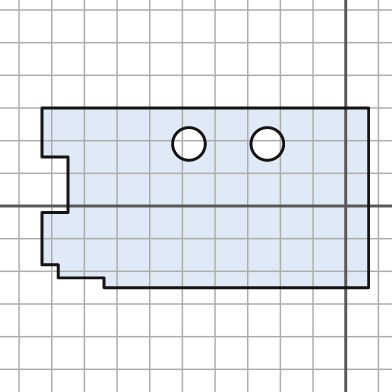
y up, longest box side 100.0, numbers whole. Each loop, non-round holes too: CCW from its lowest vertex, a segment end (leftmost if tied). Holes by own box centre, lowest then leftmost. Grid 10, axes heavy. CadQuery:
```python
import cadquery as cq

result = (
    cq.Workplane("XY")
    .moveTo(-74.0, -25.0)
    .lineTo(7.0, -25.0)
    .lineTo(7.0, 30.0)
    .lineTo(-93.0, 30.0)
    .lineTo(-93.0, 15.0)
    .lineTo(-85.0, 15.0)
    .lineTo(-85.0, -2.0)
    .lineTo(-93.0, -2.0)
    .lineTo(-93.0, -18.0)
    .lineTo(-88.0, -18.0)
    .lineTo(-88.0, -22.0)
    .lineTo(-74.0, -22.0)
    .close()
    .moveTo(-48.0, 19.0)
    .circle(5.0)
    .moveTo(-24.0, 19.0)
    .circle(5.0)
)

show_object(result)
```